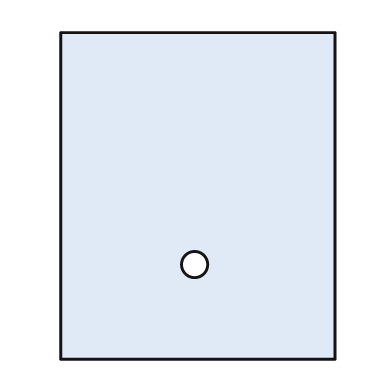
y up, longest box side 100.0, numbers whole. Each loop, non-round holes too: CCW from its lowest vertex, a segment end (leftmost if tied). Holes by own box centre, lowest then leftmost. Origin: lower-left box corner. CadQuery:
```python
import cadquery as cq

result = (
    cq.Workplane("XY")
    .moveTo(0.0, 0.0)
    .lineTo(84.0, 0.0)
    .lineTo(84.0, 100.0)
    .lineTo(0.0, 100.0)
    .close()
    .moveTo(41.0, 29.0)
    .circle(4.0)
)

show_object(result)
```